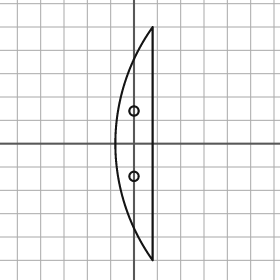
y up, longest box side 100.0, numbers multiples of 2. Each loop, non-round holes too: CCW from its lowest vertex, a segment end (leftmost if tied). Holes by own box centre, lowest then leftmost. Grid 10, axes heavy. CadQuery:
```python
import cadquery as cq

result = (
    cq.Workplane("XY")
    .moveTo(8.0, -50.0)
    .lineTo(8.0, 50.0)
    .threePointArc((-8.0, 0.0), (8.0, -50.0))
    .close()
    .moveTo(0.0, -14.0)
    .circle(2.0)
    .moveTo(0.0, 14.0)
    .circle(2.0)
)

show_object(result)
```